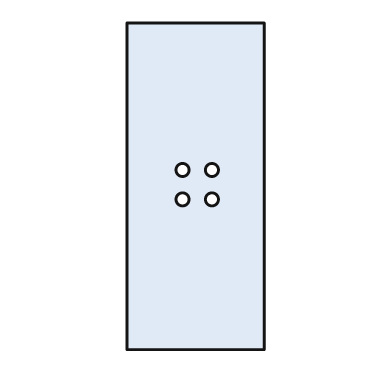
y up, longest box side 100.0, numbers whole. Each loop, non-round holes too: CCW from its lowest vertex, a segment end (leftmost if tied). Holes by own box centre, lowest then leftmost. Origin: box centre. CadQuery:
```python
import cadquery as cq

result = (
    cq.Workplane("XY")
    .moveTo(-21.0, -50.0)
    .lineTo(21.0, -50.0)
    .lineTo(21.0, 50.0)
    .lineTo(-21.0, 50.0)
    .close()
    .moveTo(-4.0, -4.0)
    .circle(2.0)
    .moveTo(5.0, -4.0)
    .circle(2.0)
    .moveTo(-4.0, 5.0)
    .circle(2.0)
    .moveTo(5.0, 5.0)
    .circle(2.0)
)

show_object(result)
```